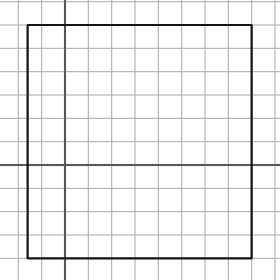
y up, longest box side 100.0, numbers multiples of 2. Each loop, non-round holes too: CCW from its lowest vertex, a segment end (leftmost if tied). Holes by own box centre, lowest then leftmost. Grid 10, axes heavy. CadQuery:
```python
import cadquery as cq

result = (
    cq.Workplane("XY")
    .moveTo(-16.0, -40.0)
    .lineTo(80.0, -40.0)
    .lineTo(80.0, 60.0)
    .lineTo(-16.0, 60.0)
    .close()
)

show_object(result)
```